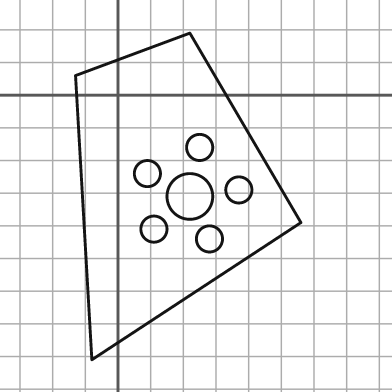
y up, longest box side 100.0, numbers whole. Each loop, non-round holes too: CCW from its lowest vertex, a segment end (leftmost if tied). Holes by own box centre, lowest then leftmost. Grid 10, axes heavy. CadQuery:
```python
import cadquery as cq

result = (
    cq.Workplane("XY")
    .moveTo(-8.0, -81.0)
    .lineTo(56.0, -39.0)
    .lineTo(22.0, 19.0)
    .lineTo(-13.0, 6.0)
    .close()
    .moveTo(28.0, -44.0)
    .circle(4.0)
    .moveTo(11.0, -41.0)
    .circle(4.0)
    .moveTo(22.0, -31.0)
    .circle(7.0)
    .moveTo(37.0, -29.0)
    .circle(4.0)
    .moveTo(9.0, -24.0)
    .circle(4.0)
    .moveTo(25.0, -16.0)
    .circle(4.0)
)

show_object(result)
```